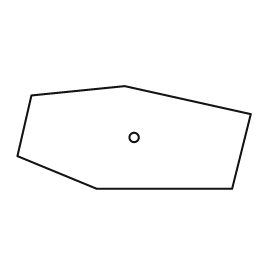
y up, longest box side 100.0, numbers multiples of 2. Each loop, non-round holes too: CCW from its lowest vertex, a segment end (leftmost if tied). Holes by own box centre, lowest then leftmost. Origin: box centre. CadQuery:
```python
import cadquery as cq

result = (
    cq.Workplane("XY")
    .moveTo(-16.0, -22.0)
    .lineTo(42.0, -22.0)
    .lineTo(50.0, 10.0)
    .lineTo(-4.0, 22.0)
    .lineTo(-44.0, 18.0)
    .lineTo(-50.0, -8.0)
    .close()
    .moveTo(0.0, 0.0)
    .circle(2.0)
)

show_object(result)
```